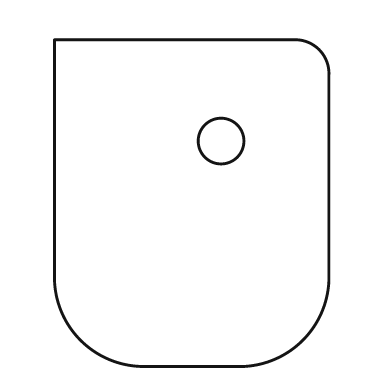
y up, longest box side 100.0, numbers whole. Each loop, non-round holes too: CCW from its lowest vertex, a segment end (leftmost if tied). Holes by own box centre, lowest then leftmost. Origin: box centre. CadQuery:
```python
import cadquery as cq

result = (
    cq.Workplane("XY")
    .moveTo(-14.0, -50.0)
    .lineTo(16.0, -50.0)
    .threePointArc((34.0, -42.0), (42.0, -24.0))
    .lineTo(42.0, 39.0)
    .threePointArc((39.0, 47.0), (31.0, 50.0))
    .lineTo(-42.0, 50.0)
    .lineTo(-42.0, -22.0)
    .threePointArc((-34.0, -42.0), (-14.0, -50.0))
    .close()
    .moveTo(9.0, 19.0)
    .circle(7.0)
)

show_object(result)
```